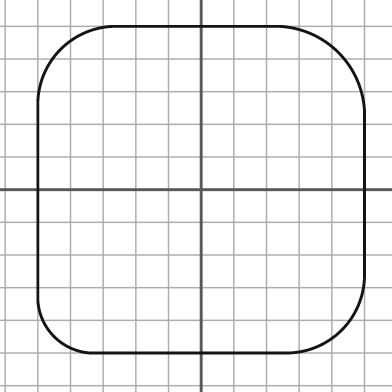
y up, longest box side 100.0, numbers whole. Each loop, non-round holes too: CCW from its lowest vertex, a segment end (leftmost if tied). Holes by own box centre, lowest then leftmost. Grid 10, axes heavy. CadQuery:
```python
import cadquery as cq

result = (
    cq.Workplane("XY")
    .moveTo(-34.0, -50.0)
    .lineTo(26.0, -50.0)
    .threePointArc((43.0, -43.0), (50.0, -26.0))
    .lineTo(50.0, 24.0)
    .threePointArc((42.0, 42.0), (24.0, 50.0))
    .lineTo(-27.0, 50.0)
    .threePointArc((-43.0, 43.0), (-50.0, 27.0))
    .lineTo(-50.0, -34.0)
    .threePointArc((-45.0, -45.0), (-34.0, -50.0))
    .close()
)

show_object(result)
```